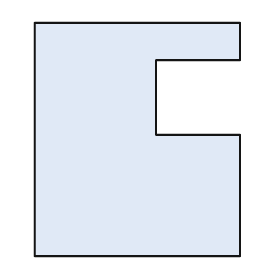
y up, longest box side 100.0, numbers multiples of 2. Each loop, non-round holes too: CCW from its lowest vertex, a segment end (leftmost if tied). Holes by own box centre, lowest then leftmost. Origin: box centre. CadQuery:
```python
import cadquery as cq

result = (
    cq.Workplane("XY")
    .moveTo(-44.0, -50.0)
    .lineTo(44.0, -50.0)
    .lineTo(44.0, 2.0)
    .lineTo(8.0, 2.0)
    .lineTo(8.0, 34.0)
    .lineTo(44.0, 34.0)
    .lineTo(44.0, 50.0)
    .lineTo(-44.0, 50.0)
    .close()
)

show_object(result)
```